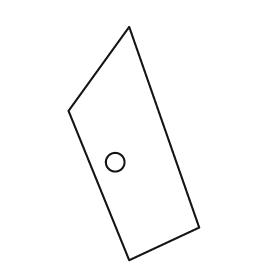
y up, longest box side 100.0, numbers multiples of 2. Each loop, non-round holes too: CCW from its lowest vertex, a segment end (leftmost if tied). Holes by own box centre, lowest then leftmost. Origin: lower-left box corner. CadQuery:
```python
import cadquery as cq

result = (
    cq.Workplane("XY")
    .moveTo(26.0, 0.0)
    .lineTo(56.0, 14.0)
    .lineTo(26.0, 100.0)
    .lineTo(0.0, 64.0)
    .close()
    .moveTo(20.0, 42.0)
    .circle(4.0)
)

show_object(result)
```